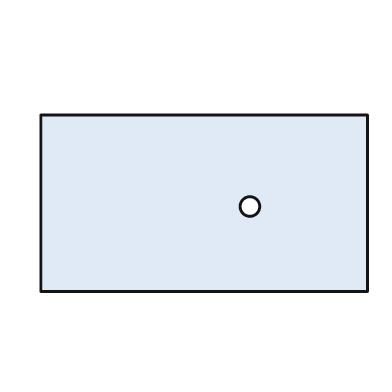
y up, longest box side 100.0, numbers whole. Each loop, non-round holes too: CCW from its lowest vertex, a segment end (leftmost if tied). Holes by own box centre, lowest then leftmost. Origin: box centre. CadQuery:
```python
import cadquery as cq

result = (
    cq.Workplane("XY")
    .moveTo(-50.0, -27.0)
    .lineTo(50.0, -27.0)
    .lineTo(50.0, 27.0)
    .lineTo(-50.0, 27.0)
    .close()
    .moveTo(14.0, -1.0)
    .circle(3.0)
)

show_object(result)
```